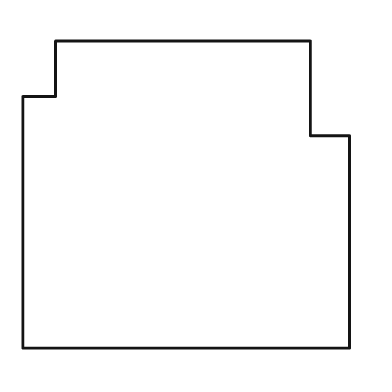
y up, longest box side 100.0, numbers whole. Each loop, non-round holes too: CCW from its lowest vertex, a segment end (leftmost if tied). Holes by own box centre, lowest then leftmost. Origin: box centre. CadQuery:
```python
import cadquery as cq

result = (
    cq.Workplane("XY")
    .moveTo(-50.0, -47.0)
    .lineTo(50.0, -47.0)
    .lineTo(50.0, 18.0)
    .lineTo(38.0, 18.0)
    .lineTo(38.0, 47.0)
    .lineTo(-40.0, 47.0)
    .lineTo(-40.0, 30.0)
    .lineTo(-50.0, 30.0)
    .close()
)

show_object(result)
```